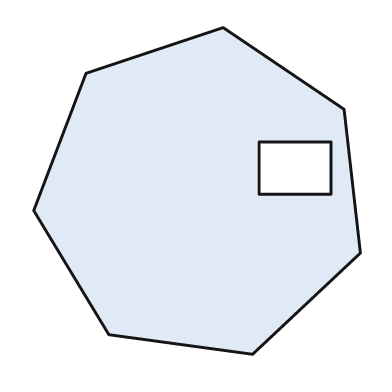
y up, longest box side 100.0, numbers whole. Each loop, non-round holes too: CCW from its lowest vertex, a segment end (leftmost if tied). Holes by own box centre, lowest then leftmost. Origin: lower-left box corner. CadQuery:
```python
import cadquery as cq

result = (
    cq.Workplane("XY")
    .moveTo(67.0, 0.0)
    .lineTo(100.0, 31.0)
    .lineTo(95.0, 75.0)
    .lineTo(58.0, 100.0)
    .lineTo(16.0, 86.0)
    .lineTo(0.0, 44.0)
    .lineTo(23.0, 6.0)
    .close()
    .moveTo(69.0, 49.0)
    .lineTo(91.0, 49.0)
    .lineTo(91.0, 65.0)
    .lineTo(69.0, 65.0)
    .close()
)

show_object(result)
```